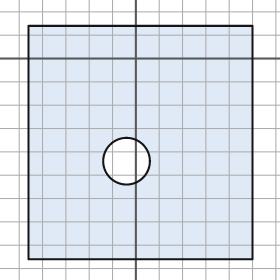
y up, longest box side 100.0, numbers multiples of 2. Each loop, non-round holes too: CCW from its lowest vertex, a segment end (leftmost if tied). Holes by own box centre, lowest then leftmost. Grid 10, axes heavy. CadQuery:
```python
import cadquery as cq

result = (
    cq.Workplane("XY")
    .moveTo(-46.0, -86.0)
    .lineTo(50.0, -86.0)
    .lineTo(50.0, 14.0)
    .lineTo(-46.0, 14.0)
    .close()
    .moveTo(-4.0, -44.0)
    .circle(10.0)
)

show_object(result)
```